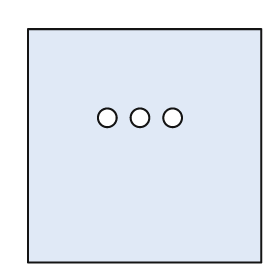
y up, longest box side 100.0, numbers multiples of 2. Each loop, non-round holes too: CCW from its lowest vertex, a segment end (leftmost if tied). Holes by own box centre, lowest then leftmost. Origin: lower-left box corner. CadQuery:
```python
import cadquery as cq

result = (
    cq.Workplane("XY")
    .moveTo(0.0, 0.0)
    .lineTo(100.0, 0.0)
    .lineTo(100.0, 100.0)
    .lineTo(0.0, 100.0)
    .close()
    .moveTo(34.0, 62.0)
    .circle(4.0)
    .moveTo(48.0, 62.0)
    .circle(4.0)
    .moveTo(62.0, 62.0)
    .circle(4.0)
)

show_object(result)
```